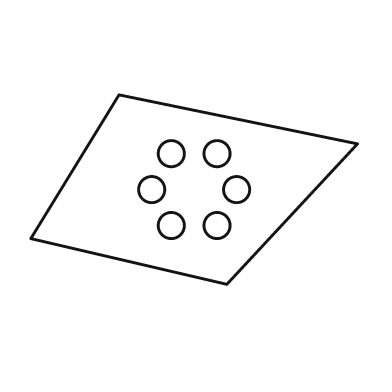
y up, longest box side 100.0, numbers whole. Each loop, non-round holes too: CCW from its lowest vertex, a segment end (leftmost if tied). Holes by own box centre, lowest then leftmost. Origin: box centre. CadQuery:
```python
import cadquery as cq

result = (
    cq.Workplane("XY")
    .moveTo(10.0, -29.0)
    .lineTo(50.0, 14.0)
    .lineTo(-23.0, 29.0)
    .lineTo(-50.0, -15.0)
    .close()
    .moveTo(-7.0, -11.0)
    .circle(4.0)
    .moveTo(7.0, -11.0)
    .circle(4.0)
    .moveTo(-13.0, 0.0)
    .circle(4.0)
    .moveTo(13.0, 0.0)
    .circle(4.0)
    .moveTo(-7.0, 11.0)
    .circle(4.0)
    .moveTo(7.0, 11.0)
    .circle(4.0)
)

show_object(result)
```